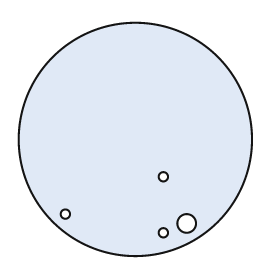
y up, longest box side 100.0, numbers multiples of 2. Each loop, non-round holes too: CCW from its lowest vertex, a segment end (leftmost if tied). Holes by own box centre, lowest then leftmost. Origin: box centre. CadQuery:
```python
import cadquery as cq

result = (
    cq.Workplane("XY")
    .moveTo(0.0, 0.0)
    .circle(50.0)
    .moveTo(12.0, -40.0)
    .circle(2.0)
    .moveTo(22.0, -36.0)
    .circle(4.0)
    .moveTo(-30.0, -32.0)
    .circle(2.0)
    .moveTo(12.0, -16.0)
    .circle(2.0)
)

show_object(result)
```